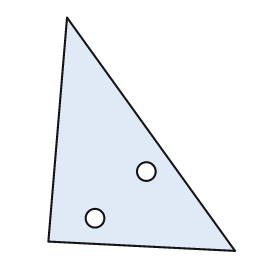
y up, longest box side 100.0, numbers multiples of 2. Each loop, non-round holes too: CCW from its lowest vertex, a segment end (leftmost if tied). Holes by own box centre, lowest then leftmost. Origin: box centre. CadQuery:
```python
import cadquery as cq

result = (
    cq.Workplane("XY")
    .moveTo(40.0, -50.0)
    .lineTo(-32.0, 50.0)
    .lineTo(-40.0, -46.0)
    .close()
    .moveTo(-20.0, -36.0)
    .circle(4.0)
    .moveTo(2.0, -16.0)
    .circle(4.0)
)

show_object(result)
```